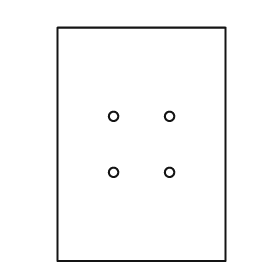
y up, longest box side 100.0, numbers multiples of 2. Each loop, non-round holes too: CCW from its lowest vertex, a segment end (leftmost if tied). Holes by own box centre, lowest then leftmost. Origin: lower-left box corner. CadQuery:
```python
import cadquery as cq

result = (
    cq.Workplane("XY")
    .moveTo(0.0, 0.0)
    .lineTo(72.0, 0.0)
    .lineTo(72.0, 100.0)
    .lineTo(0.0, 100.0)
    .close()
    .moveTo(24.0, 38.0)
    .circle(2.0)
    .moveTo(48.0, 38.0)
    .circle(2.0)
    .moveTo(24.0, 62.0)
    .circle(2.0)
    .moveTo(48.0, 62.0)
    .circle(2.0)
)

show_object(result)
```